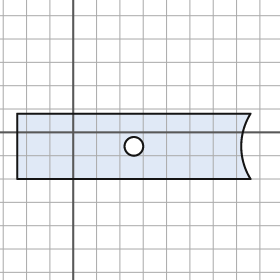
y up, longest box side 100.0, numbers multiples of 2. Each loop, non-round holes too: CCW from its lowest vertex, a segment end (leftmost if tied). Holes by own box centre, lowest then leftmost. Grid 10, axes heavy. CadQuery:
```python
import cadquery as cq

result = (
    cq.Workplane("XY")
    .moveTo(-24.0, -20.0)
    .lineTo(76.0, -20.0)
    .threePointArc((72.0, -6.0), (76.0, 8.0))
    .lineTo(-24.0, 8.0)
    .close()
    .moveTo(26.0, -6.0)
    .circle(4.0)
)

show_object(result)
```